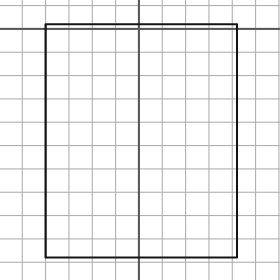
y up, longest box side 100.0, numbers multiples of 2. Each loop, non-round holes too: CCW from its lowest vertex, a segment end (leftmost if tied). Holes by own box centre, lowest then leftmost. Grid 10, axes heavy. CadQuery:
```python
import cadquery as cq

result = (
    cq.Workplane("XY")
    .moveTo(-40.0, -98.0)
    .lineTo(42.0, -98.0)
    .lineTo(42.0, 2.0)
    .lineTo(-40.0, 2.0)
    .close()
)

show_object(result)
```